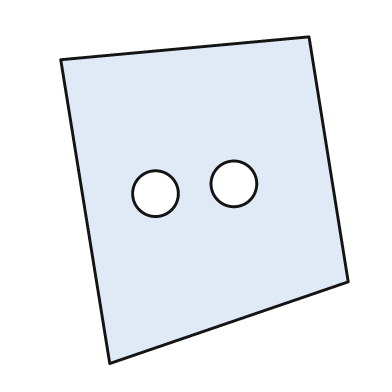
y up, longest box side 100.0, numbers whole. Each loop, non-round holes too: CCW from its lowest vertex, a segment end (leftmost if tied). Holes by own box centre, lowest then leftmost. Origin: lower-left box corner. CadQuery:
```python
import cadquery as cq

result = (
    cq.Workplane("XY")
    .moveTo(15.0, 0.0)
    .lineTo(88.0, 25.0)
    .lineTo(76.0, 100.0)
    .lineTo(0.0, 93.0)
    .close()
    .moveTo(29.0, 52.0)
    .circle(7.0)
    .moveTo(53.0, 55.0)
    .circle(7.0)
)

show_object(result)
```